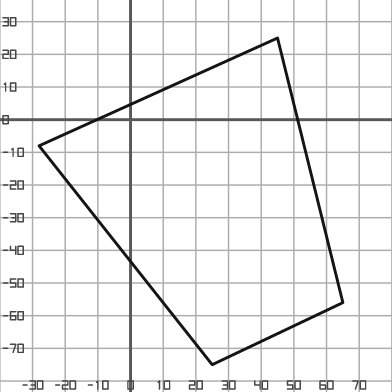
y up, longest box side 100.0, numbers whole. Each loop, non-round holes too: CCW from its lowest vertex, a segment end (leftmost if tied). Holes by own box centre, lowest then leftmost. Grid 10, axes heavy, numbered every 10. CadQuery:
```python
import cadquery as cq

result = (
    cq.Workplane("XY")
    .moveTo(25.0, -75.0)
    .lineTo(65.0, -56.0)
    .lineTo(45.0, 25.0)
    .lineTo(-28.0, -8.0)
    .close()
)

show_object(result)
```